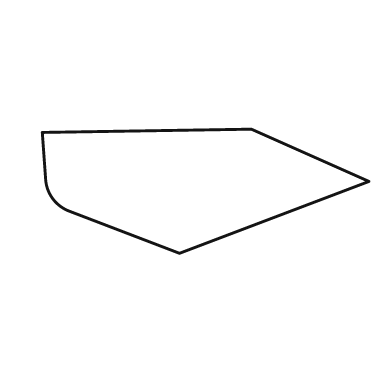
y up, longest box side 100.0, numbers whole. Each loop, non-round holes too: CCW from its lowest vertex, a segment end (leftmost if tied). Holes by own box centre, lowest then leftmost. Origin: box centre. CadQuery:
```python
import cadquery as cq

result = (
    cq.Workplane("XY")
    .moveTo(-8.0, -19.0)
    .lineTo(50.0, 3.0)
    .lineTo(14.0, 19.0)
    .lineTo(-50.0, 18.0)
    .lineTo(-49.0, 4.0)
    .threePointArc((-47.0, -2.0), (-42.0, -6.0))
    .close()
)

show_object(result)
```